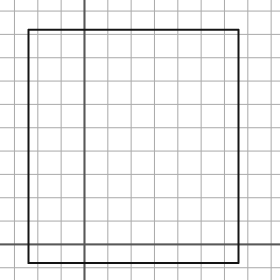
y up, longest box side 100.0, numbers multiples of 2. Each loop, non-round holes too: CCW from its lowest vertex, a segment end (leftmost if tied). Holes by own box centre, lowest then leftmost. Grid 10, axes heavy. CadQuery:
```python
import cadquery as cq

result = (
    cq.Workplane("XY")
    .moveTo(-24.0, -8.0)
    .lineTo(66.0, -8.0)
    .lineTo(66.0, 92.0)
    .lineTo(-24.0, 92.0)
    .close()
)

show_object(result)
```